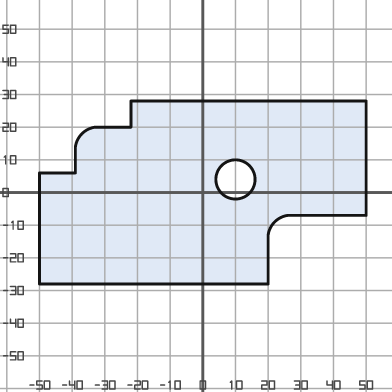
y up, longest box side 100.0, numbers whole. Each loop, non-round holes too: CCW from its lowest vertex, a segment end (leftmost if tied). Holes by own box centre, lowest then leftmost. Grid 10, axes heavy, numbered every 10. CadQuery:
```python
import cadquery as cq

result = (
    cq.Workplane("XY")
    .moveTo(-50.0, -28.0)
    .lineTo(20.0, -28.0)
    .lineTo(20.0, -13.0)
    .threePointArc((22.0, -9.0), (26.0, -7.0))
    .lineTo(50.0, -7.0)
    .lineTo(50.0, 28.0)
    .lineTo(-22.0, 28.0)
    .lineTo(-22.0, 20.0)
    .lineTo(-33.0, 20.0)
    .threePointArc((-37.0, 18.0), (-39.0, 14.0))
    .lineTo(-39.0, 6.0)
    .lineTo(-50.0, 6.0)
    .close()
    .moveTo(10.0, 4.0)
    .circle(6.0)
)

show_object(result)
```